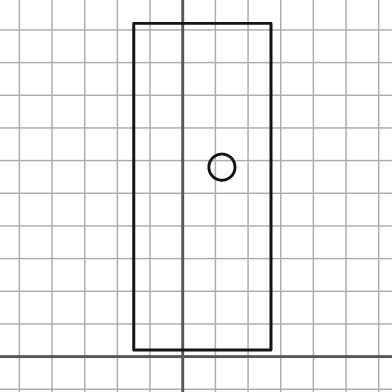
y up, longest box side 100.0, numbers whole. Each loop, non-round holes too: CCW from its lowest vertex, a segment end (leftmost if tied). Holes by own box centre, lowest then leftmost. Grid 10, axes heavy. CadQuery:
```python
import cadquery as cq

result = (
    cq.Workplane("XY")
    .moveTo(-15.0, 2.0)
    .lineTo(27.0, 2.0)
    .lineTo(27.0, 102.0)
    .lineTo(-15.0, 102.0)
    .close()
    .moveTo(12.0, 58.0)
    .circle(4.0)
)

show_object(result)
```